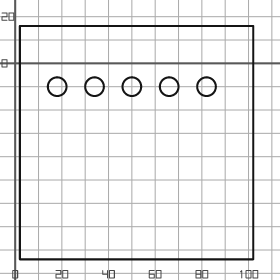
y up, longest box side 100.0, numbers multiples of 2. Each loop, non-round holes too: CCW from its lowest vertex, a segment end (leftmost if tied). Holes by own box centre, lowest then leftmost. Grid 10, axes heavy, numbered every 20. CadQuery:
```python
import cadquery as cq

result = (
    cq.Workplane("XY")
    .moveTo(2.0, -84.0)
    .lineTo(102.0, -84.0)
    .lineTo(102.0, 16.0)
    .lineTo(2.0, 16.0)
    .close()
    .moveTo(18.0, -10.0)
    .circle(4.0)
    .moveTo(34.0, -10.0)
    .circle(4.0)
    .moveTo(50.0, -10.0)
    .circle(4.0)
    .moveTo(66.0, -10.0)
    .circle(4.0)
    .moveTo(82.0, -10.0)
    .circle(4.0)
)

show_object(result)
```